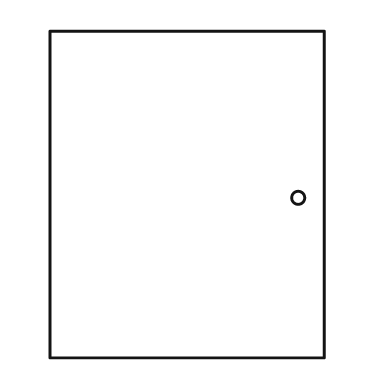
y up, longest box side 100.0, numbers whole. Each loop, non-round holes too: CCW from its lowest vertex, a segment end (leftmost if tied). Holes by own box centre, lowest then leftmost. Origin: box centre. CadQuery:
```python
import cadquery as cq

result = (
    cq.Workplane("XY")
    .moveTo(-42.0, -50.0)
    .lineTo(42.0, -50.0)
    .lineTo(42.0, 50.0)
    .lineTo(-42.0, 50.0)
    .close()
    .moveTo(34.0, -1.0)
    .circle(2.0)
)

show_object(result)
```